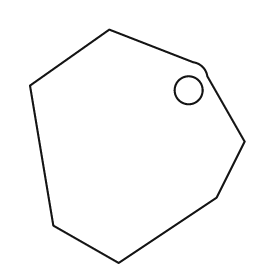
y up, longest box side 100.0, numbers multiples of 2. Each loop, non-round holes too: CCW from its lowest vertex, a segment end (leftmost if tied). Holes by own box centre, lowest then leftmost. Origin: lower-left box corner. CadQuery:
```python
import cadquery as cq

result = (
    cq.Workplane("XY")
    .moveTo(38.0, 0.0)
    .lineTo(80.0, 28.0)
    .lineTo(92.0, 52.0)
    .lineTo(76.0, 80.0)
    .threePointArc((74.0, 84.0), (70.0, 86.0))
    .lineTo(34.0, 100.0)
    .lineTo(0.0, 76.0)
    .lineTo(10.0, 16.0)
    .close()
    .moveTo(68.0, 74.0)
    .circle(6.0)
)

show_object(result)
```